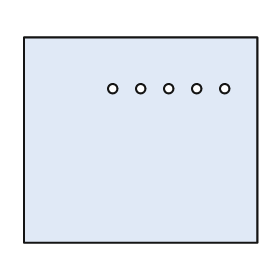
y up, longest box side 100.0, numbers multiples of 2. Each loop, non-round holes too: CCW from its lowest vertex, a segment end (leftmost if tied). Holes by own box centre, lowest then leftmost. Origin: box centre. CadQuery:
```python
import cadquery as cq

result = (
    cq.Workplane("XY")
    .moveTo(-50.0, -44.0)
    .lineTo(50.0, -44.0)
    .lineTo(50.0, 44.0)
    .lineTo(-50.0, 44.0)
    .close()
    .moveTo(-12.0, 22.0)
    .circle(2.0)
    .moveTo(0.0, 22.0)
    .circle(2.0)
    .moveTo(12.0, 22.0)
    .circle(2.0)
    .moveTo(24.0, 22.0)
    .circle(2.0)
    .moveTo(36.0, 22.0)
    .circle(2.0)
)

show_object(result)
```